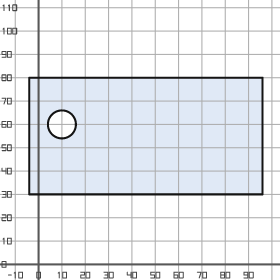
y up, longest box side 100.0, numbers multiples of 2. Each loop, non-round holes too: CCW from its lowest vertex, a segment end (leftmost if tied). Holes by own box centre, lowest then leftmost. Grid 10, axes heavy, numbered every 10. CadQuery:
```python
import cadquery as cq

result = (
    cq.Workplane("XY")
    .moveTo(-4.0, 30.0)
    .lineTo(96.0, 30.0)
    .lineTo(96.0, 80.0)
    .lineTo(-4.0, 80.0)
    .close()
    .moveTo(10.0, 60.0)
    .circle(6.0)
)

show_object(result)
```